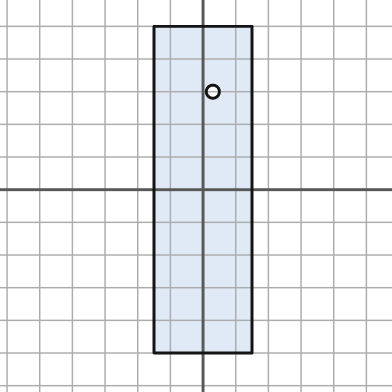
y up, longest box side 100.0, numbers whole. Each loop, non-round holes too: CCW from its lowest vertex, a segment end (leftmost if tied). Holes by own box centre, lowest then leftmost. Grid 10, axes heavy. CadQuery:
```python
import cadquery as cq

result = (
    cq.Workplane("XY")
    .moveTo(-15.0, -50.0)
    .lineTo(15.0, -50.0)
    .lineTo(15.0, 50.0)
    .lineTo(-15.0, 50.0)
    .close()
    .moveTo(3.0, 30.0)
    .circle(2.0)
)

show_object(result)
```